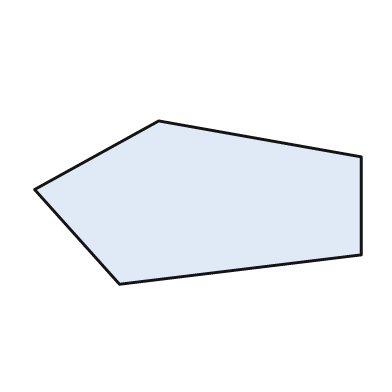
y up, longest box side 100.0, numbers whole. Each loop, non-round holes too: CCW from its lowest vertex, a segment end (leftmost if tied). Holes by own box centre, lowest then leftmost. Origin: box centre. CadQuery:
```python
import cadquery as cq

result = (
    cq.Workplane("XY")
    .moveTo(-24.0, -25.0)
    .lineTo(50.0, -16.0)
    .lineTo(50.0, 14.0)
    .lineTo(-12.0, 25.0)
    .lineTo(-50.0, 4.0)
    .close()
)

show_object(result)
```